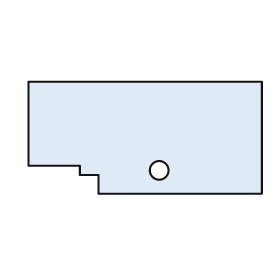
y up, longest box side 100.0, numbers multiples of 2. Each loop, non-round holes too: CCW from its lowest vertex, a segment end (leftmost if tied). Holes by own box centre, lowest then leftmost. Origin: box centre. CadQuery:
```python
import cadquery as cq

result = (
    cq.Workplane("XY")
    .moveTo(-20.0, -24.0)
    .lineTo(50.0, -24.0)
    .lineTo(50.0, 24.0)
    .lineTo(-50.0, 24.0)
    .lineTo(-50.0, -12.0)
    .lineTo(-28.0, -12.0)
    .lineTo(-28.0, -16.0)
    .lineTo(-20.0, -16.0)
    .close()
    .moveTo(6.0, -14.0)
    .circle(4.0)
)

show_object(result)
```